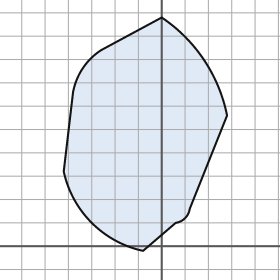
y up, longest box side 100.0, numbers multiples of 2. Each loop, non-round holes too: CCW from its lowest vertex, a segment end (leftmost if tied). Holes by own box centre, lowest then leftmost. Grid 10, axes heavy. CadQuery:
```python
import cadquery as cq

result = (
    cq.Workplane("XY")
    .moveTo(-8.0, -2.0)
    .lineTo(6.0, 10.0)
    .threePointArc((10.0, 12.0), (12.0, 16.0))
    .lineTo(28.0, 56.0)
    .threePointArc((18.0, 80.0), (0.0, 98.0))
    .lineTo(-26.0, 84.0)
    .threePointArc((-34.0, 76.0), (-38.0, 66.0))
    .lineTo(-42.0, 32.0)
    .threePointArc((-30.0, 10.0), (-8.0, -2.0))
    .close()
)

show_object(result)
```